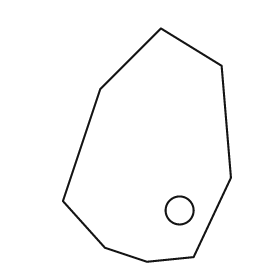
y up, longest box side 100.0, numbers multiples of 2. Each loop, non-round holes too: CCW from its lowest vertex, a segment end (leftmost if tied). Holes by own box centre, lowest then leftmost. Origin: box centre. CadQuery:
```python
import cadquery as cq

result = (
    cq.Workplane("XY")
    .moveTo(0.0, -50.0)
    .lineTo(20.0, -48.0)
    .lineTo(36.0, -14.0)
    .lineTo(32.0, 34.0)
    .lineTo(6.0, 50.0)
    .lineTo(-20.0, 24.0)
    .lineTo(-36.0, -24.0)
    .lineTo(-18.0, -44.0)
    .close()
    .moveTo(14.0, -28.0)
    .circle(6.0)
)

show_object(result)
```